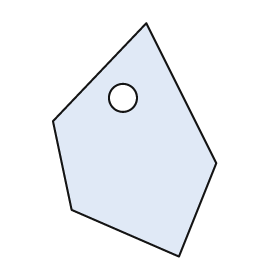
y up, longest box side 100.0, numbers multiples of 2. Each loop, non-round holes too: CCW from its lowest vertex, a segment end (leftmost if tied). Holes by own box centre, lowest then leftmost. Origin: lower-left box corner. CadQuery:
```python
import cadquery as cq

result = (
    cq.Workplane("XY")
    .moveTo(54.0, 0.0)
    .lineTo(70.0, 40.0)
    .lineTo(40.0, 100.0)
    .lineTo(0.0, 58.0)
    .lineTo(8.0, 20.0)
    .close()
    .moveTo(30.0, 68.0)
    .circle(6.0)
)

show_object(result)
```